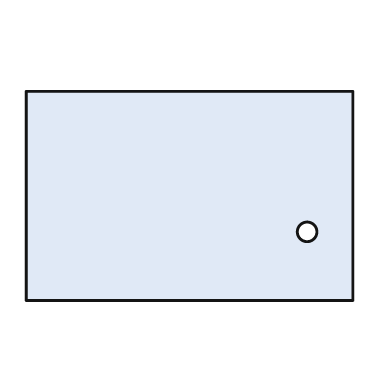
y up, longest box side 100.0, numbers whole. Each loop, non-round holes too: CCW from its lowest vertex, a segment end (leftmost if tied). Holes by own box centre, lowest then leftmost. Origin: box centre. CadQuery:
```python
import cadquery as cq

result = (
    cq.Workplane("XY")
    .moveTo(-50.0, -32.0)
    .lineTo(50.0, -32.0)
    .lineTo(50.0, 32.0)
    .lineTo(-50.0, 32.0)
    .close()
    .moveTo(36.0, -11.0)
    .circle(3.0)
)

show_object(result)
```